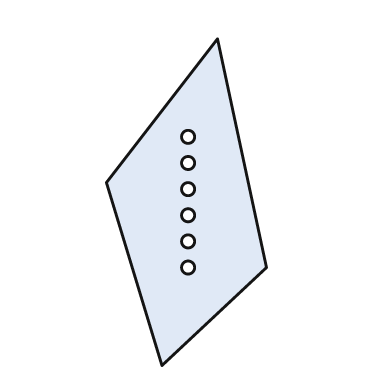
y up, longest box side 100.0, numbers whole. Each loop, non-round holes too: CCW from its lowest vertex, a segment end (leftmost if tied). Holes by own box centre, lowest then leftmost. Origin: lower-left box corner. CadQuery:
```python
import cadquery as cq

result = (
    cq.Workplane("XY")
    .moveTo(17.0, 0.0)
    .lineTo(49.0, 30.0)
    .lineTo(34.0, 100.0)
    .lineTo(0.0, 56.0)
    .close()
    .moveTo(25.0, 30.0)
    .circle(2.0)
    .moveTo(25.0, 38.0)
    .circle(2.0)
    .moveTo(25.0, 46.0)
    .circle(2.0)
    .moveTo(25.0, 54.0)
    .circle(2.0)
    .moveTo(25.0, 62.0)
    .circle(2.0)
    .moveTo(25.0, 70.0)
    .circle(2.0)
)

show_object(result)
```